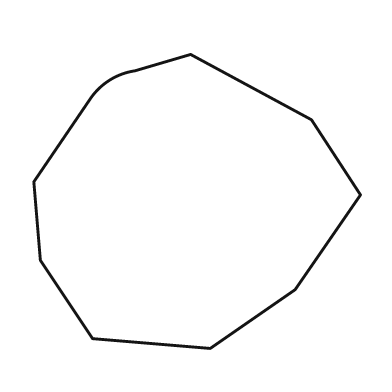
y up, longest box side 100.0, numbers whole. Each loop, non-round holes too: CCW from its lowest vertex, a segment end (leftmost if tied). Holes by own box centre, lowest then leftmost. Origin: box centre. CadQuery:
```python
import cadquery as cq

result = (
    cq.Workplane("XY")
    .moveTo(4.0, -45.0)
    .lineTo(30.0, -27.0)
    .lineTo(50.0, 2.0)
    .lineTo(35.0, 25.0)
    .lineTo(-2.0, 45.0)
    .lineTo(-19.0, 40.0)
    .threePointArc((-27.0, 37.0), (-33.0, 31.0))
    .lineTo(-50.0, 6.0)
    .lineTo(-48.0, -18.0)
    .lineTo(-32.0, -42.0)
    .close()
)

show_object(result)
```